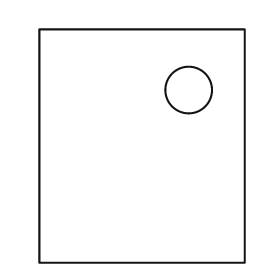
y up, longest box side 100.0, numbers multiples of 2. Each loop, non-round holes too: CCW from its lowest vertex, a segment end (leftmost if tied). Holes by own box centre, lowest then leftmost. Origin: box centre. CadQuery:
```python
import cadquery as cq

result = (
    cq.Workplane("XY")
    .moveTo(-44.0, -50.0)
    .lineTo(44.0, -50.0)
    .lineTo(44.0, 50.0)
    .lineTo(-44.0, 50.0)
    .close()
    .moveTo(20.0, 24.0)
    .circle(10.0)
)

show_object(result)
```